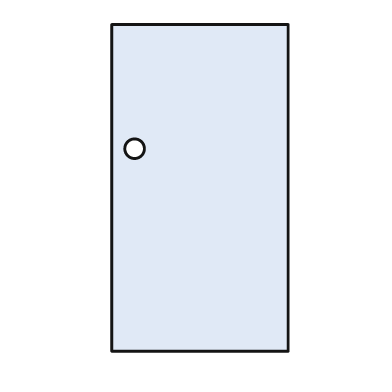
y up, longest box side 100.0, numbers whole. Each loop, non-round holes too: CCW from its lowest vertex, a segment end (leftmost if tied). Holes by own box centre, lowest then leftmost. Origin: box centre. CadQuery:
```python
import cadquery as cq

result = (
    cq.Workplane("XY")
    .moveTo(-27.0, -50.0)
    .lineTo(27.0, -50.0)
    .lineTo(27.0, 50.0)
    .lineTo(-27.0, 50.0)
    .close()
    .moveTo(-20.0, 12.0)
    .circle(3.0)
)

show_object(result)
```